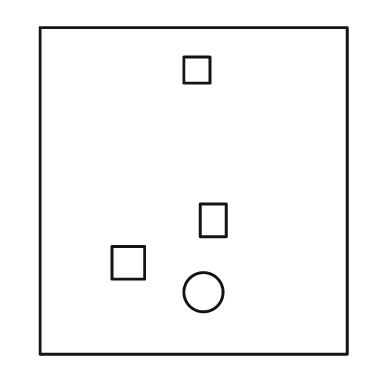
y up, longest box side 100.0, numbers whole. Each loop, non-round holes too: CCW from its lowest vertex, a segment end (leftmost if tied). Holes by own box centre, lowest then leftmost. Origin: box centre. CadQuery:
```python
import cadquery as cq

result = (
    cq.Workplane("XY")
    .moveTo(-47.0, -50.0)
    .lineTo(47.0, -50.0)
    .lineTo(47.0, 50.0)
    .lineTo(-47.0, 50.0)
    .close()
    .moveTo(3.0, -31.0)
    .circle(6.0)
    .moveTo(-25.0, -27.0)
    .lineTo(-15.0, -27.0)
    .lineTo(-15.0, -17.0)
    .lineTo(-25.0, -17.0)
    .close()
    .moveTo(2.0, -14.0)
    .lineTo(10.0, -14.0)
    .lineTo(10.0, -4.0)
    .lineTo(2.0, -4.0)
    .close()
    .moveTo(-3.0, 33.0)
    .lineTo(5.0, 33.0)
    .lineTo(5.0, 41.0)
    .lineTo(-3.0, 41.0)
    .close()
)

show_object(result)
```